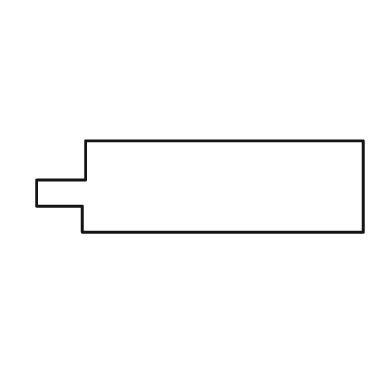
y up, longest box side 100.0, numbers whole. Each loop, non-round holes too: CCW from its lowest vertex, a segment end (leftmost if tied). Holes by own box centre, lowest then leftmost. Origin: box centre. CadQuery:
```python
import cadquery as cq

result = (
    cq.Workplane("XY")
    .moveTo(-36.0, -14.0)
    .lineTo(50.0, -14.0)
    .lineTo(50.0, 14.0)
    .lineTo(-35.0, 14.0)
    .lineTo(-35.0, 2.0)
    .lineTo(-50.0, 2.0)
    .lineTo(-50.0, -6.0)
    .lineTo(-36.0, -6.0)
    .close()
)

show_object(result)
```